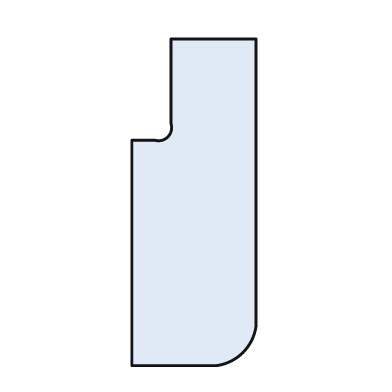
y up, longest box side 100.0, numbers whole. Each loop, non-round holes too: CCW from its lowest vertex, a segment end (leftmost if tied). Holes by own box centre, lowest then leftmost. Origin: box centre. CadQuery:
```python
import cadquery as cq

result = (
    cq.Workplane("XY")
    .moveTo(-19.0, -50.0)
    .lineTo(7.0, -50.0)
    .threePointArc((15.0, -46.0), (19.0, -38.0))
    .lineTo(19.0, 50.0)
    .lineTo(-7.0, 50.0)
    .lineTo(-7.0, 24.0)
    .threePointArc((-8.0, 20.0), (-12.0, 19.0))
    .lineTo(-19.0, 19.0)
    .close()
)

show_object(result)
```